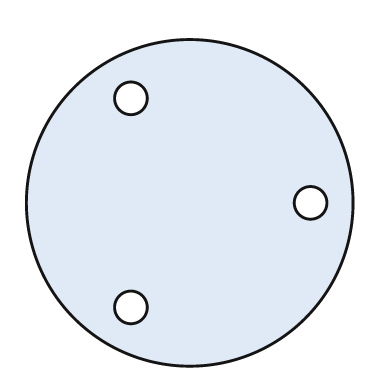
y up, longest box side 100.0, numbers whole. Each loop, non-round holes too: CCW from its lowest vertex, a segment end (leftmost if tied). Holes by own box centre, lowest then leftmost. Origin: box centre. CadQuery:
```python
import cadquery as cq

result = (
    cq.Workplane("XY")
    .moveTo(0.0, 0.0)
    .circle(50.0)
    .moveTo(-18.0, -32.0)
    .circle(5.0)
    .moveTo(37.0, 0.0)
    .circle(5.0)
    .moveTo(-18.0, 32.0)
    .circle(5.0)
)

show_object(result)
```